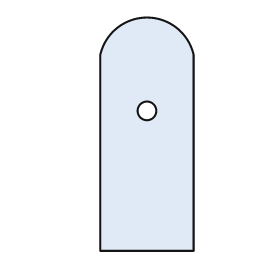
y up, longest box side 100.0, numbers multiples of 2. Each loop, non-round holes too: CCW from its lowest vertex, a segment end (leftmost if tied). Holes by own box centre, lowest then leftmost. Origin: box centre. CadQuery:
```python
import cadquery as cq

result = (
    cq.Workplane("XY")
    .moveTo(-20.0, -50.0)
    .lineTo(20.0, -50.0)
    .lineTo(20.0, 34.0)
    .threePointArc((0.0, 50.0), (-20.0, 34.0))
    .close()
    .moveTo(0.0, 10.0)
    .circle(4.0)
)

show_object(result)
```